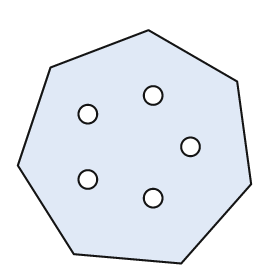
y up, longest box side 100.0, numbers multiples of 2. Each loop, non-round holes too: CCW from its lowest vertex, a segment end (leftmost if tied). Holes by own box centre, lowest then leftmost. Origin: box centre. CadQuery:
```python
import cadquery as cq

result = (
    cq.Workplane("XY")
    .moveTo(20.0, -50.0)
    .lineTo(50.0, -16.0)
    .lineTo(44.0, 28.0)
    .lineTo(6.0, 50.0)
    .lineTo(-36.0, 34.0)
    .lineTo(-50.0, -8.0)
    .lineTo(-26.0, -46.0)
    .close()
    .moveTo(8.0, -22.0)
    .circle(4.0)
    .moveTo(-20.0, -14.0)
    .circle(4.0)
    .moveTo(24.0, 0.0)
    .circle(4.0)
    .moveTo(-20.0, 14.0)
    .circle(4.0)
    .moveTo(8.0, 22.0)
    .circle(4.0)
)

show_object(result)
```